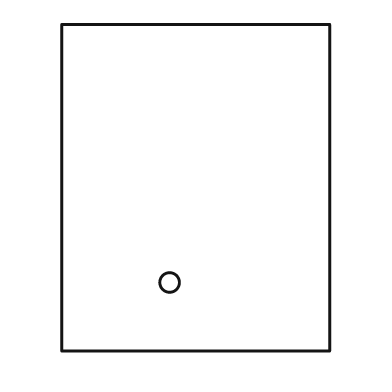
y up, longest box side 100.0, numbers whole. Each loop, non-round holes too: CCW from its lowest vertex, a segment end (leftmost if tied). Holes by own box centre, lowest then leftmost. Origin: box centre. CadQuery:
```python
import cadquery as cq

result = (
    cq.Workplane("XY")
    .moveTo(-41.0, -50.0)
    .lineTo(41.0, -50.0)
    .lineTo(41.0, 50.0)
    .lineTo(-41.0, 50.0)
    .close()
    .moveTo(-8.0, -29.0)
    .circle(3.0)
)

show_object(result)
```